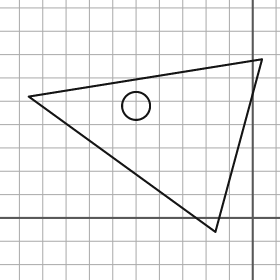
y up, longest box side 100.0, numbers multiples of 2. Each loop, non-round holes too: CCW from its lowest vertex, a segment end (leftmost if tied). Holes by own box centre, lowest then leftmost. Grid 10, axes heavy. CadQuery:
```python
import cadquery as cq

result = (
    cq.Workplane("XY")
    .moveTo(-16.0, -6.0)
    .lineTo(4.0, 68.0)
    .lineTo(-96.0, 52.0)
    .close()
    .moveTo(-50.0, 48.0)
    .circle(6.0)
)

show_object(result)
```